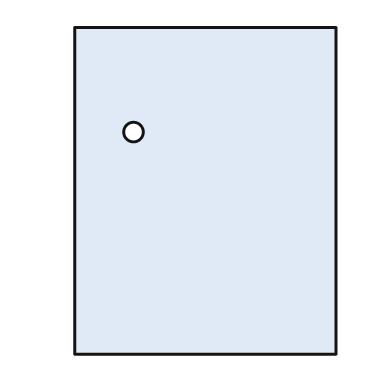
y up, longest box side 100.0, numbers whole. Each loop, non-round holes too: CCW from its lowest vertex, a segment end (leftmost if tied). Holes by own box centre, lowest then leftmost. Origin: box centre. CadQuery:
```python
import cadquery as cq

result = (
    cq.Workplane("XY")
    .moveTo(-40.0, -50.0)
    .lineTo(40.0, -50.0)
    .lineTo(40.0, 50.0)
    .lineTo(-40.0, 50.0)
    .close()
    .moveTo(-22.0, 18.0)
    .circle(3.0)
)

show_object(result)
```